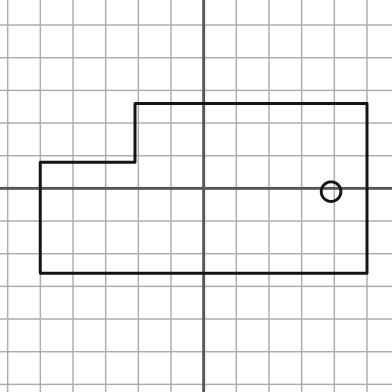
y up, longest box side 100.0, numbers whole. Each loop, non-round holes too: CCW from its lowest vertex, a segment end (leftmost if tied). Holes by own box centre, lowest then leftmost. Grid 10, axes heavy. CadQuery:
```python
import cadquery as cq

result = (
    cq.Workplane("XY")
    .moveTo(-50.0, -26.0)
    .lineTo(50.0, -26.0)
    .lineTo(50.0, 26.0)
    .lineTo(-21.0, 26.0)
    .lineTo(-21.0, 8.0)
    .lineTo(-50.0, 8.0)
    .close()
    .moveTo(39.0, -1.0)
    .circle(3.0)
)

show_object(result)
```